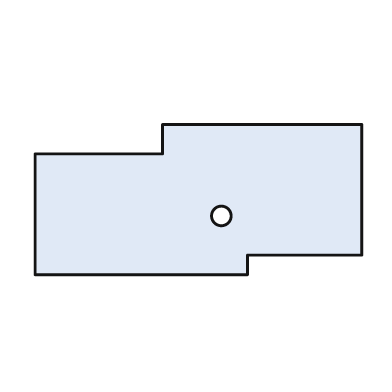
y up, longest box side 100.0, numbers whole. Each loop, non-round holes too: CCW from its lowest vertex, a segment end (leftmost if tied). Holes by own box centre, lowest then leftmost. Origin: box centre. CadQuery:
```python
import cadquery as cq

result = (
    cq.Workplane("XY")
    .moveTo(-50.0, -23.0)
    .lineTo(15.0, -23.0)
    .lineTo(15.0, -17.0)
    .lineTo(50.0, -17.0)
    .lineTo(50.0, 23.0)
    .lineTo(-11.0, 23.0)
    .lineTo(-11.0, 14.0)
    .lineTo(-50.0, 14.0)
    .close()
    .moveTo(7.0, -5.0)
    .circle(3.0)
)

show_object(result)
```